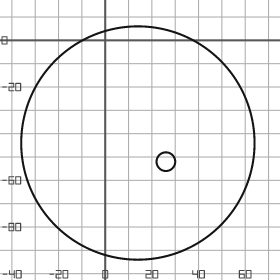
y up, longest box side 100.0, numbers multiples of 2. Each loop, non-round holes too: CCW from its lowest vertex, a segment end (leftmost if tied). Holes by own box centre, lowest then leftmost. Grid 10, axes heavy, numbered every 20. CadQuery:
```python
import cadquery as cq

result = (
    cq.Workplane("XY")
    .moveTo(14.0, -44.0)
    .circle(50.0)
    .moveTo(26.0, -52.0)
    .circle(4.0)
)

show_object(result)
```